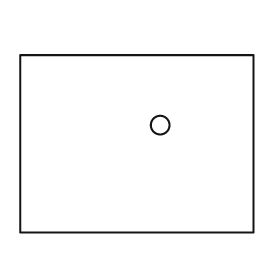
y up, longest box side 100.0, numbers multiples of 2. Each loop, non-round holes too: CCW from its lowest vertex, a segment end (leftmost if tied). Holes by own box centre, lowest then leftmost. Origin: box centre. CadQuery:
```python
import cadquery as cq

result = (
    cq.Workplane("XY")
    .moveTo(-50.0, -38.0)
    .lineTo(50.0, -38.0)
    .lineTo(50.0, 38.0)
    .lineTo(-50.0, 38.0)
    .close()
    .moveTo(10.0, 8.0)
    .circle(4.0)
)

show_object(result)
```